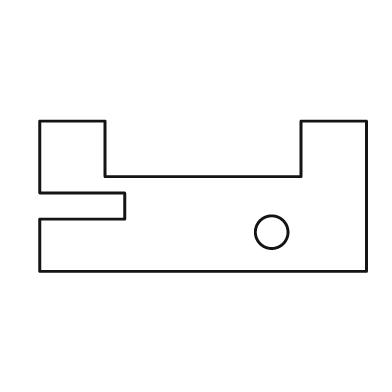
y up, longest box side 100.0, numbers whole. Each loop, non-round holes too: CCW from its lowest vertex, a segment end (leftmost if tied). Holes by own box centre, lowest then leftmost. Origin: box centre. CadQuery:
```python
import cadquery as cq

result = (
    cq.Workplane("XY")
    .moveTo(-50.0, -23.0)
    .lineTo(50.0, -23.0)
    .lineTo(50.0, 23.0)
    .lineTo(30.0, 23.0)
    .lineTo(30.0, 6.0)
    .lineTo(-30.0, 6.0)
    .lineTo(-30.0, 23.0)
    .lineTo(-50.0, 23.0)
    .lineTo(-50.0, 1.0)
    .lineTo(-24.0, 1.0)
    .lineTo(-24.0, -7.0)
    .lineTo(-50.0, -7.0)
    .close()
    .moveTo(21.0, -11.0)
    .circle(5.0)
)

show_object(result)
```